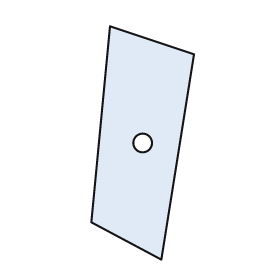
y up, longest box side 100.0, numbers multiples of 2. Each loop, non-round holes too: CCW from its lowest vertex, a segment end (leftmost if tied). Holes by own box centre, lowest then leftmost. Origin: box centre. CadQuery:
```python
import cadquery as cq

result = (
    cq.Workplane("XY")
    .moveTo(8.0, -50.0)
    .lineTo(22.0, 38.0)
    .lineTo(-14.0, 50.0)
    .lineTo(-22.0, -34.0)
    .close()
    .moveTo(0.0, 0.0)
    .circle(4.0)
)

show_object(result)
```